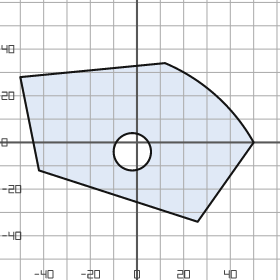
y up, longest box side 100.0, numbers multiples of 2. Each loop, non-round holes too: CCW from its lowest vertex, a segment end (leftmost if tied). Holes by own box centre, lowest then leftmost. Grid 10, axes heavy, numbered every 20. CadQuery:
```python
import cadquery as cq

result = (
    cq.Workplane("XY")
    .moveTo(26.0, -34.0)
    .lineTo(50.0, 0.0)
    .threePointArc((34.0, 20.0), (12.0, 34.0))
    .lineTo(-50.0, 28.0)
    .lineTo(-42.0, -12.0)
    .close()
    .moveTo(-2.0, -4.0)
    .circle(8.0)
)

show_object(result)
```